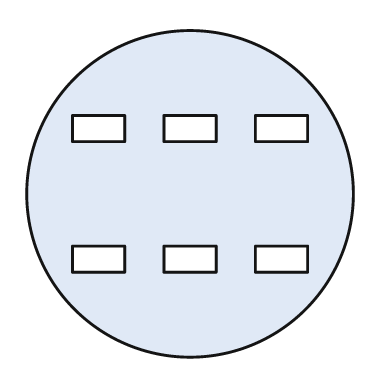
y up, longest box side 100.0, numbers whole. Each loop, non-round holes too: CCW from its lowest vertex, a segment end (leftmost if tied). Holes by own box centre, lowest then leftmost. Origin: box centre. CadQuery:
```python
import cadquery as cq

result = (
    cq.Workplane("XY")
    .moveTo(0.0, 0.0)
    .circle(50.0)
    .moveTo(-36.0, -24.0)
    .lineTo(-20.0, -24.0)
    .lineTo(-20.0, -16.0)
    .lineTo(-36.0, -16.0)
    .close()
    .moveTo(-8.0, -24.0)
    .lineTo(8.0, -24.0)
    .lineTo(8.0, -16.0)
    .lineTo(-8.0, -16.0)
    .close()
    .moveTo(20.0, -24.0)
    .lineTo(36.0, -24.0)
    .lineTo(36.0, -16.0)
    .lineTo(20.0, -16.0)
    .close()
    .moveTo(-36.0, 16.0)
    .lineTo(-20.0, 16.0)
    .lineTo(-20.0, 24.0)
    .lineTo(-36.0, 24.0)
    .close()
    .moveTo(-8.0, 16.0)
    .lineTo(8.0, 16.0)
    .lineTo(8.0, 24.0)
    .lineTo(-8.0, 24.0)
    .close()
    .moveTo(20.0, 16.0)
    .lineTo(36.0, 16.0)
    .lineTo(36.0, 24.0)
    .lineTo(20.0, 24.0)
    .close()
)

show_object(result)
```